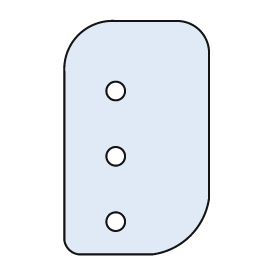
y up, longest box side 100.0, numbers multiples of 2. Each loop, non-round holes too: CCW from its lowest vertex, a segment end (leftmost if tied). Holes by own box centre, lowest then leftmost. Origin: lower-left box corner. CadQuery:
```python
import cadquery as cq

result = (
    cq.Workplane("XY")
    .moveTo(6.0, 0.0)
    .lineTo(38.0, 0.0)
    .threePointArc((54.0, 8.0), (62.0, 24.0))
    .lineTo(62.0, 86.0)
    .threePointArc((58.0, 96.0), (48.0, 100.0))
    .lineTo(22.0, 100.0)
    .threePointArc((6.0, 94.0), (0.0, 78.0))
    .lineTo(0.0, 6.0)
    .threePointArc((2.0, 2.0), (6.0, 0.0))
    .close()
    .moveTo(22.0, 14.0)
    .circle(4.0)
    .moveTo(22.0, 42.0)
    .circle(4.0)
    .moveTo(22.0, 70.0)
    .circle(4.0)
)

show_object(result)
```